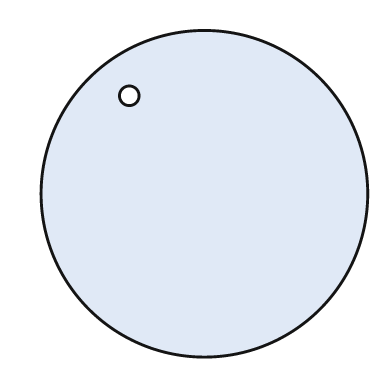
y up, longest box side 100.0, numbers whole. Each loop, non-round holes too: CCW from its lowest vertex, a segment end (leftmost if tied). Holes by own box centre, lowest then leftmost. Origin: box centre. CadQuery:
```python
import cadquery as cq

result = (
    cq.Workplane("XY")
    .moveTo(0.0, 0.0)
    .circle(50.0)
    .moveTo(-23.0, 30.0)
    .circle(3.0)
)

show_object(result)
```